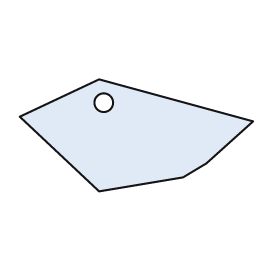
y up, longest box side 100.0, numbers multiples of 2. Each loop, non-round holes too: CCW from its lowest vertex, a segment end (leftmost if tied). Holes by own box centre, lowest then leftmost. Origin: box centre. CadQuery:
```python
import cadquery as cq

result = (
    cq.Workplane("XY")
    .moveTo(-16.0, -24.0)
    .lineTo(20.0, -18.0)
    .lineTo(30.0, -12.0)
    .lineTo(50.0, 6.0)
    .lineTo(-16.0, 24.0)
    .lineTo(-50.0, 8.0)
    .close()
    .moveTo(-14.0, 14.0)
    .circle(4.0)
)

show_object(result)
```